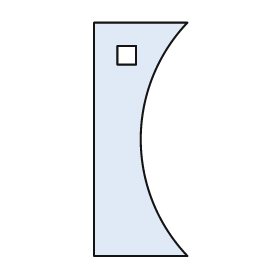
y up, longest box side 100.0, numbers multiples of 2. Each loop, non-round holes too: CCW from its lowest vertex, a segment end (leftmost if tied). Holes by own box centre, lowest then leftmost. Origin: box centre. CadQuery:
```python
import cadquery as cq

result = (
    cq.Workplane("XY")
    .moveTo(-20.0, -50.0)
    .lineTo(20.0, -50.0)
    .threePointArc((0.0, 0.0), (20.0, 50.0))
    .lineTo(-20.0, 50.0)
    .close()
    .moveTo(-10.0, 32.0)
    .lineTo(-2.0, 32.0)
    .lineTo(-2.0, 40.0)
    .lineTo(-10.0, 40.0)
    .close()
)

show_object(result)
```